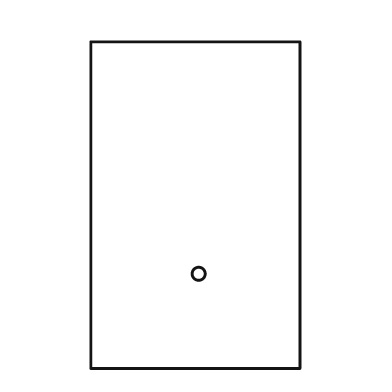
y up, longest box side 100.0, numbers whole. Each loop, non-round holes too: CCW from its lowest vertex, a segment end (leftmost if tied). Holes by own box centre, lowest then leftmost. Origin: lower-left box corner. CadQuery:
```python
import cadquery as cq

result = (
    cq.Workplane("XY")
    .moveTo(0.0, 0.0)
    .lineTo(64.0, 0.0)
    .lineTo(64.0, 100.0)
    .lineTo(0.0, 100.0)
    .close()
    .moveTo(33.0, 29.0)
    .circle(2.0)
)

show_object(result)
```